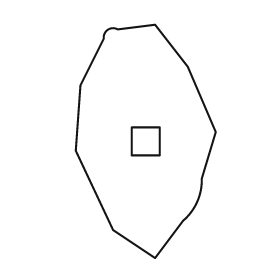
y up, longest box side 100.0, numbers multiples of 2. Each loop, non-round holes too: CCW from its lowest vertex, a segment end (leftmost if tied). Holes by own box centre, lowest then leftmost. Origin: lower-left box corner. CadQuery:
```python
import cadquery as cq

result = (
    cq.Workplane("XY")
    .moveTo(34.0, 0.0)
    .lineTo(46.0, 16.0)
    .threePointArc((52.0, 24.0), (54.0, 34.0))
    .lineTo(60.0, 54.0)
    .lineTo(48.0, 82.0)
    .lineTo(34.0, 100.0)
    .lineTo(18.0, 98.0)
    .threePointArc((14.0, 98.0), (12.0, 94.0))
    .lineTo(2.0, 74.0)
    .lineTo(0.0, 46.0)
    .lineTo(16.0, 12.0)
    .close()
    .moveTo(24.0, 44.0)
    .lineTo(36.0, 44.0)
    .lineTo(36.0, 56.0)
    .lineTo(24.0, 56.0)
    .close()
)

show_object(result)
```